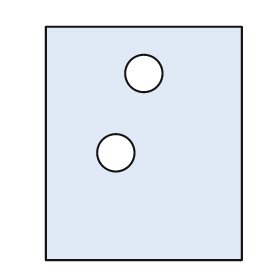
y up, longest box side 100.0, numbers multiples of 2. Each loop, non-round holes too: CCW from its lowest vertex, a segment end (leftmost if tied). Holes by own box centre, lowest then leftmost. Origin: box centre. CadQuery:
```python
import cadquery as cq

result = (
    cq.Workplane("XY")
    .moveTo(-42.0, -50.0)
    .lineTo(42.0, -50.0)
    .lineTo(42.0, 50.0)
    .lineTo(-42.0, 50.0)
    .close()
    .moveTo(-12.0, -4.0)
    .circle(8.0)
    .moveTo(0.0, 30.0)
    .circle(8.0)
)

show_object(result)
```